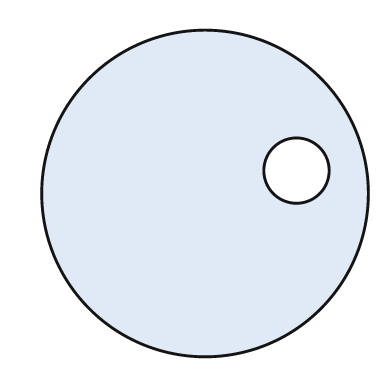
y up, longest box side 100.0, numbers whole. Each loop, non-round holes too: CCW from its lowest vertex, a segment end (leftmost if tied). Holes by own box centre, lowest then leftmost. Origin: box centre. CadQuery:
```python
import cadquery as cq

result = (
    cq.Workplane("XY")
    .moveTo(0.0, 0.0)
    .circle(50.0)
    .moveTo(28.0, 7.0)
    .circle(10.0)
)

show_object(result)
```